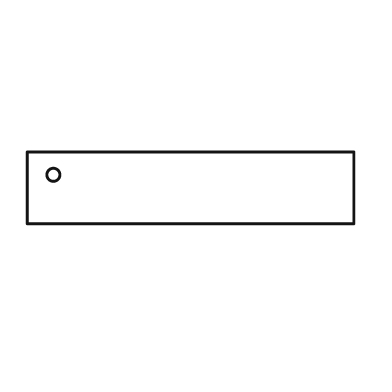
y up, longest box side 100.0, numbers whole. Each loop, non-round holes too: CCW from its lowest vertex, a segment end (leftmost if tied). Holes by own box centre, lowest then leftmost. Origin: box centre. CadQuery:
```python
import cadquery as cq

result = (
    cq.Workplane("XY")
    .moveTo(-50.0, -11.0)
    .lineTo(50.0, -11.0)
    .lineTo(50.0, 11.0)
    .lineTo(-50.0, 11.0)
    .close()
    .moveTo(-42.0, 4.0)
    .circle(2.0)
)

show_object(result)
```